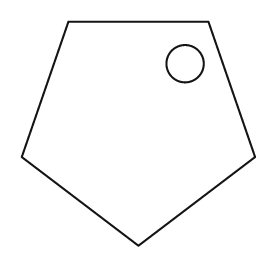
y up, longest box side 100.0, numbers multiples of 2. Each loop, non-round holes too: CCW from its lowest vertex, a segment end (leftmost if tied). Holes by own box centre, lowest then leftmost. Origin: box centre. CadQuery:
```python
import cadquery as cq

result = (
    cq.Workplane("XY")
    .moveTo(0.0, -48.0)
    .lineTo(50.0, -10.0)
    .lineTo(30.0, 48.0)
    .lineTo(-30.0, 48.0)
    .lineTo(-50.0, -10.0)
    .close()
    .moveTo(20.0, 30.0)
    .circle(8.0)
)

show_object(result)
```